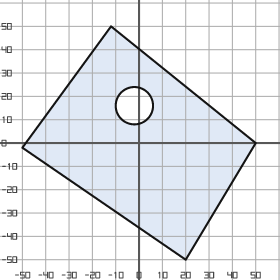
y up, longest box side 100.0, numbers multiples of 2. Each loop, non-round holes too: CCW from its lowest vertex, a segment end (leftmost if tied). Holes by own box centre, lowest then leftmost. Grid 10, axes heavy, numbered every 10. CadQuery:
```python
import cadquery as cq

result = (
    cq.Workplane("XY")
    .moveTo(20.0, -50.0)
    .lineTo(50.0, 0.0)
    .lineTo(-12.0, 50.0)
    .lineTo(-50.0, -2.0)
    .close()
    .moveTo(-2.0, 16.0)
    .circle(8.0)
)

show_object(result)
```